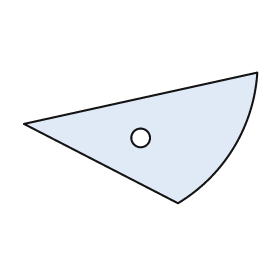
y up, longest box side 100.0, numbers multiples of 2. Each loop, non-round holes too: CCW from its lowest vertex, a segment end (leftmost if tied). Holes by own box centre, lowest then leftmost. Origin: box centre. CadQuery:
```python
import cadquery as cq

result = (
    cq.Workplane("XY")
    .moveTo(16.0, -28.0)
    .threePointArc((40.0, -4.0), (50.0, 28.0))
    .lineTo(-50.0, 6.0)
    .close()
    .moveTo(0.0, 0.0)
    .circle(4.0)
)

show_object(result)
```